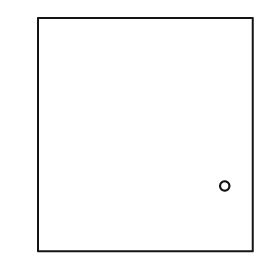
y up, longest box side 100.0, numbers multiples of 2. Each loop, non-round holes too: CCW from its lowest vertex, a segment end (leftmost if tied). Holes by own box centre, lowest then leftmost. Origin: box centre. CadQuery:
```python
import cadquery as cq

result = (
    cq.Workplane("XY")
    .moveTo(-46.0, -50.0)
    .lineTo(46.0, -50.0)
    .lineTo(46.0, 50.0)
    .lineTo(-46.0, 50.0)
    .close()
    .moveTo(34.0, -22.0)
    .circle(2.0)
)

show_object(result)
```